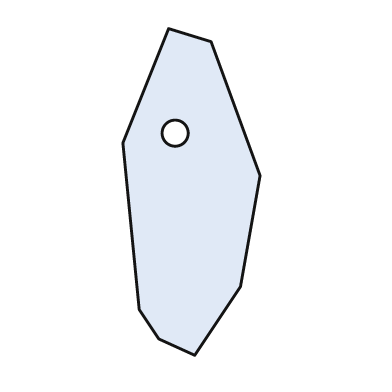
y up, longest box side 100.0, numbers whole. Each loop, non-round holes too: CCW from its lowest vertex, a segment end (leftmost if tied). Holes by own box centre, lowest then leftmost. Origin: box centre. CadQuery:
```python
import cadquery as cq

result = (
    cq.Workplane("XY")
    .moveTo(1.0, -50.0)
    .lineTo(15.0, -29.0)
    .lineTo(21.0, 5.0)
    .lineTo(6.0, 46.0)
    .lineTo(-7.0, 50.0)
    .lineTo(-21.0, 15.0)
    .lineTo(-16.0, -36.0)
    .lineTo(-10.0, -45.0)
    .close()
    .moveTo(-5.0, 18.0)
    .circle(4.0)
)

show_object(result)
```